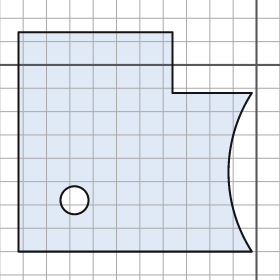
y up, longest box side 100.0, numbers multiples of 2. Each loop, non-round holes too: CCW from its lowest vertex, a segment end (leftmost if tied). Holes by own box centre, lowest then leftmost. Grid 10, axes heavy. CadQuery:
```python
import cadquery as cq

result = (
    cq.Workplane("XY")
    .moveTo(-102.0, -80.0)
    .lineTo(-2.0, -80.0)
    .threePointArc((-12.0, -46.0), (-2.0, -12.0))
    .lineTo(-36.0, -12.0)
    .lineTo(-36.0, 14.0)
    .lineTo(-102.0, 14.0)
    .close()
    .moveTo(-78.0, -58.0)
    .circle(6.0)
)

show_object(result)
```